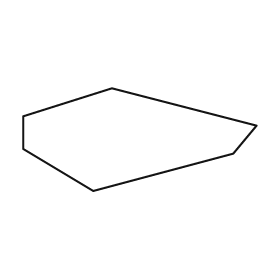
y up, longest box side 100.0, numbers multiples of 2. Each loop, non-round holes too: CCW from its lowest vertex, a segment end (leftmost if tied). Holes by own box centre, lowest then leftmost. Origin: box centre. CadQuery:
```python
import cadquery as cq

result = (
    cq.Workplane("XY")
    .moveTo(-20.0, -22.0)
    .lineTo(40.0, -6.0)
    .lineTo(50.0, 6.0)
    .lineTo(-12.0, 22.0)
    .lineTo(-50.0, 10.0)
    .lineTo(-50.0, -4.0)
    .close()
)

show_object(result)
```